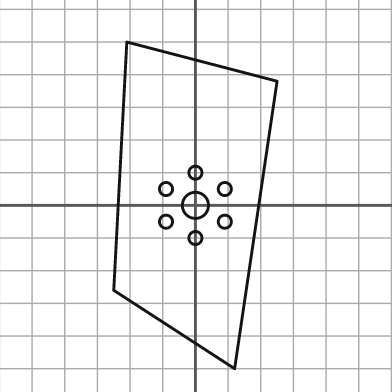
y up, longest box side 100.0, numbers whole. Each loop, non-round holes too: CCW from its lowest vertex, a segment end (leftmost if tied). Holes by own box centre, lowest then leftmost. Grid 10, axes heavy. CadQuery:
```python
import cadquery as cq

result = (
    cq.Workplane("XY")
    .moveTo(12.0, -50.0)
    .lineTo(25.0, 38.0)
    .lineTo(-21.0, 50.0)
    .lineTo(-25.0, -26.0)
    .close()
    .moveTo(0.0, -10.0)
    .circle(2.0)
    .moveTo(-9.0, -5.0)
    .circle(2.0)
    .moveTo(9.0, -5.0)
    .circle(2.0)
    .moveTo(0.0, 0.0)
    .circle(4.0)
    .moveTo(-9.0, 5.0)
    .circle(2.0)
    .moveTo(9.0, 5.0)
    .circle(2.0)
    .moveTo(0.0, 10.0)
    .circle(2.0)
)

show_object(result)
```